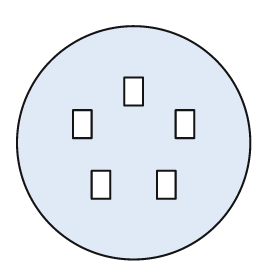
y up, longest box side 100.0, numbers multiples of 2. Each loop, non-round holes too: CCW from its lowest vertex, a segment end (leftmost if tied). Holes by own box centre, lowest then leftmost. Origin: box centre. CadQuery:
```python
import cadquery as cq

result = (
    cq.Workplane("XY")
    .moveTo(0.0, 0.0)
    .circle(50.0)
    .moveTo(-18.0, -24.0)
    .lineTo(-10.0, -24.0)
    .lineTo(-10.0, -12.0)
    .lineTo(-18.0, -12.0)
    .close()
    .moveTo(10.0, -24.0)
    .lineTo(18.0, -24.0)
    .lineTo(18.0, -12.0)
    .lineTo(10.0, -12.0)
    .close()
    .moveTo(-26.0, 2.0)
    .lineTo(-18.0, 2.0)
    .lineTo(-18.0, 14.0)
    .lineTo(-26.0, 14.0)
    .close()
    .moveTo(18.0, 2.0)
    .lineTo(26.0, 2.0)
    .lineTo(26.0, 14.0)
    .lineTo(18.0, 14.0)
    .close()
    .moveTo(-4.0, 16.0)
    .lineTo(4.0, 16.0)
    .lineTo(4.0, 28.0)
    .lineTo(-4.0, 28.0)
    .close()
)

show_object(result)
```